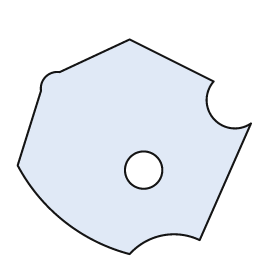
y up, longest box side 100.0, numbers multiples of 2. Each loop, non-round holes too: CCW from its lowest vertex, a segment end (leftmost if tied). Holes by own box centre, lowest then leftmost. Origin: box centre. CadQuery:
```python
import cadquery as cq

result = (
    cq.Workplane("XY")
    .moveTo(-2.0, -46.0)
    .threePointArc((12.0, -38.0), (28.0, -40.0))
    .lineTo(50.0, 10.0)
    .threePointArc((34.0, 12.0), (34.0, 28.0))
    .lineTo(-2.0, 46.0)
    .lineTo(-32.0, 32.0)
    .threePointArc((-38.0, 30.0), (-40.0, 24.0))
    .lineTo(-50.0, -8.0)
    .threePointArc((-30.0, -32.0), (-2.0, -46.0))
    .close()
    .moveTo(4.0, -10.0)
    .circle(8.0)
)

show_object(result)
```